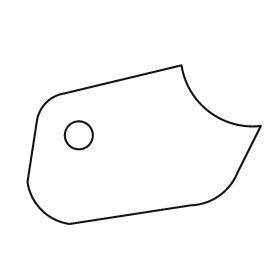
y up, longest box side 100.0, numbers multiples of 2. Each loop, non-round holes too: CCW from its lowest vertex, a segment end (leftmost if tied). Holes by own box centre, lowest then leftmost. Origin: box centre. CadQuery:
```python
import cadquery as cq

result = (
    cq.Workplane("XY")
    .moveTo(-32.0, -34.0)
    .lineTo(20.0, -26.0)
    .threePointArc((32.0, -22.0), (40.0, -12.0))
    .lineTo(50.0, 8.0)
    .threePointArc((28.0, 14.0), (16.0, 34.0))
    .lineTo(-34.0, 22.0)
    .threePointArc((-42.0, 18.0), (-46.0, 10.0))
    .lineTo(-50.0, -16.0)
    .threePointArc((-44.0, -28.0), (-32.0, -34.0))
    .close()
    .moveTo(-28.0, 4.0)
    .circle(6.0)
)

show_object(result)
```